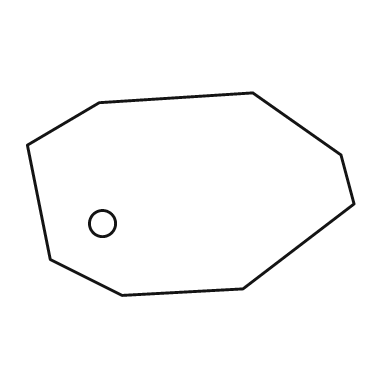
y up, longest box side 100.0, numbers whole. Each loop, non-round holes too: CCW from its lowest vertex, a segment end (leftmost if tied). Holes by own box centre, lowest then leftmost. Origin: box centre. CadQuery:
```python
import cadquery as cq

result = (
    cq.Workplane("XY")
    .moveTo(-21.0, -31.0)
    .lineTo(16.0, -29.0)
    .lineTo(50.0, -3.0)
    .lineTo(46.0, 12.0)
    .lineTo(19.0, 31.0)
    .lineTo(-28.0, 28.0)
    .lineTo(-50.0, 15.0)
    .lineTo(-43.0, -20.0)
    .close()
    .moveTo(-27.0, -9.0)
    .circle(4.0)
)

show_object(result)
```